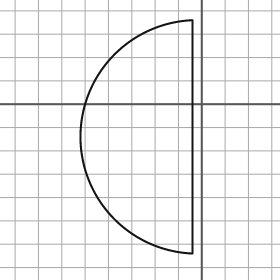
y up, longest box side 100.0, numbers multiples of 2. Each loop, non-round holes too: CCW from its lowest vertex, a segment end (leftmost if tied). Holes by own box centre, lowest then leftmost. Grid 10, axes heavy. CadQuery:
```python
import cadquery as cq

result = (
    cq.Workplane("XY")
    .moveTo(-4.0, -64.0)
    .lineTo(-4.0, 36.0)
    .threePointArc((-52.0, -14.0), (-4.0, -64.0))
    .close()
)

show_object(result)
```